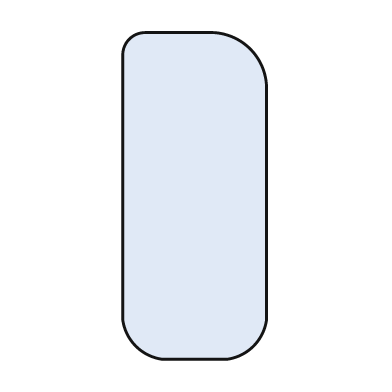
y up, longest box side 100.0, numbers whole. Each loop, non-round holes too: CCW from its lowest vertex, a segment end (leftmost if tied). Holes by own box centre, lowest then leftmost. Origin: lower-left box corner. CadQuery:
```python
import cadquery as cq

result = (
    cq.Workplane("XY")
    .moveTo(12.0, 0.0)
    .lineTo(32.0, 0.0)
    .threePointArc((40.0, 4.0), (44.0, 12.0))
    .lineTo(44.0, 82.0)
    .threePointArc((39.0, 95.0), (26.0, 100.0))
    .lineTo(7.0, 100.0)
    .threePointArc((2.0, 98.0), (0.0, 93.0))
    .lineTo(0.0, 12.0)
    .threePointArc((4.0, 4.0), (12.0, 0.0))
    .close()
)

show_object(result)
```